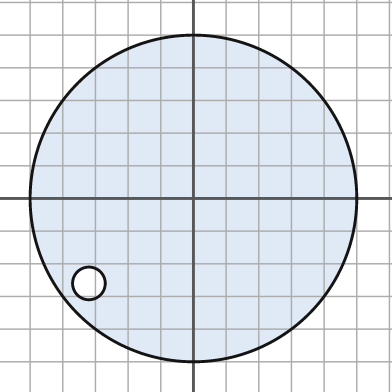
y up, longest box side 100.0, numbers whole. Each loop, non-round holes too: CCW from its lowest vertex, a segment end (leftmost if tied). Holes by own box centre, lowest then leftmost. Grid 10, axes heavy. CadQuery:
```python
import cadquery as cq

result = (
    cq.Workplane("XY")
    .moveTo(0.0, 0.0)
    .circle(50.0)
    .moveTo(-32.0, -26.0)
    .circle(5.0)
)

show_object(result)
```